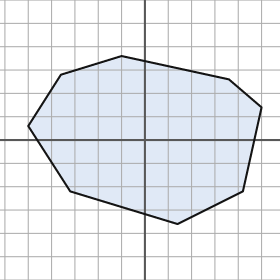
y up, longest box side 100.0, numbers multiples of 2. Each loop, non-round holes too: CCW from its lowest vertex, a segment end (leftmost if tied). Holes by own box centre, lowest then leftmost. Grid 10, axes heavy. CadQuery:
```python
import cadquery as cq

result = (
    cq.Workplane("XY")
    .moveTo(14.0, -36.0)
    .lineTo(42.0, -22.0)
    .lineTo(50.0, 14.0)
    .lineTo(36.0, 26.0)
    .lineTo(-10.0, 36.0)
    .lineTo(-36.0, 28.0)
    .lineTo(-50.0, 6.0)
    .lineTo(-32.0, -22.0)
    .close()
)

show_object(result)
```